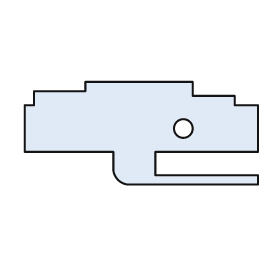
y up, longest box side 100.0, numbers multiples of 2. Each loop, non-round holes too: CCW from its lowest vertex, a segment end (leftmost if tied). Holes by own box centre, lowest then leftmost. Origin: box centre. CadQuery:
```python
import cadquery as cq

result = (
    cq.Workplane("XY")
    .moveTo(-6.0, -22.0)
    .lineTo(50.0, -22.0)
    .lineTo(50.0, -18.0)
    .lineTo(6.0, -18.0)
    .lineTo(6.0, -8.0)
    .lineTo(50.0, -8.0)
    .lineTo(50.0, 12.0)
    .lineTo(40.0, 12.0)
    .lineTo(40.0, 16.0)
    .lineTo(22.0, 16.0)
    .lineTo(22.0, 22.0)
    .lineTo(-24.0, 22.0)
    .lineTo(-24.0, 18.0)
    .lineTo(-46.0, 18.0)
    .lineTo(-46.0, 12.0)
    .lineTo(-50.0, 12.0)
    .lineTo(-50.0, -8.0)
    .lineTo(-12.0, -8.0)
    .lineTo(-12.0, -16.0)
    .threePointArc((-10.0, -20.0), (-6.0, -22.0))
    .close()
    .moveTo(18.0, 2.0)
    .circle(4.0)
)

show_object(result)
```